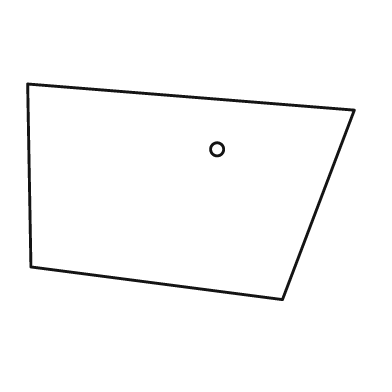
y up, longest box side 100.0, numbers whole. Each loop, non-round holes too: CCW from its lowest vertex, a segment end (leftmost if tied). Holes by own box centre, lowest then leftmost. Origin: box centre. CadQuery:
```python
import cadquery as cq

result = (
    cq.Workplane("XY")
    .moveTo(28.0, -33.0)
    .lineTo(50.0, 25.0)
    .lineTo(-50.0, 33.0)
    .lineTo(-49.0, -23.0)
    .close()
    .moveTo(8.0, 13.0)
    .circle(2.0)
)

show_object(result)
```